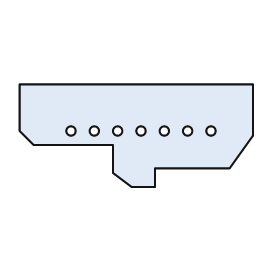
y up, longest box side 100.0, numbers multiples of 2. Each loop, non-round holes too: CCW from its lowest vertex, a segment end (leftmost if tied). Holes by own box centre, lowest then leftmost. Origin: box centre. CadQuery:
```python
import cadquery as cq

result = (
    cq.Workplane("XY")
    .moveTo(-2.0, -22.0)
    .lineTo(8.0, -22.0)
    .lineTo(8.0, -14.0)
    .lineTo(40.0, -14.0)
    .lineTo(50.0, 0.0)
    .lineTo(50.0, 22.0)
    .lineTo(-50.0, 22.0)
    .lineTo(-50.0, 2.0)
    .lineTo(-44.0, -4.0)
    .lineTo(-10.0, -4.0)
    .lineTo(-10.0, -16.0)
    .close()
    .moveTo(-28.0, 2.0)
    .circle(2.0)
    .moveTo(-18.0, 2.0)
    .circle(2.0)
    .moveTo(-8.0, 2.0)
    .circle(2.0)
    .moveTo(2.0, 2.0)
    .circle(2.0)
    .moveTo(12.0, 2.0)
    .circle(2.0)
    .moveTo(22.0, 2.0)
    .circle(2.0)
    .moveTo(32.0, 2.0)
    .circle(2.0)
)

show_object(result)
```